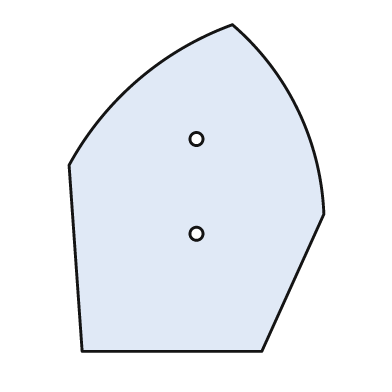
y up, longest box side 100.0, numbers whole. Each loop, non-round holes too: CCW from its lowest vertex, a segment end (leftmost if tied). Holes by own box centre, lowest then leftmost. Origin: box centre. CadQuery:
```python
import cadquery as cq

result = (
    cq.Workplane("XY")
    .moveTo(-35.0, -50.0)
    .lineTo(20.0, -50.0)
    .lineTo(39.0, -8.0)
    .threePointArc((31.0, 24.0), (11.0, 50.0))
    .threePointArc((-18.0, 33.0), (-39.0, 7.0))
    .close()
    .moveTo(0.0, -14.0)
    .circle(2.0)
    .moveTo(0.0, 15.0)
    .circle(2.0)
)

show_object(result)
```